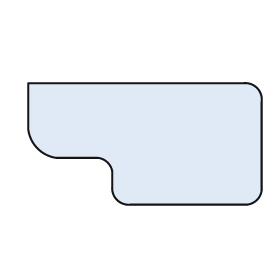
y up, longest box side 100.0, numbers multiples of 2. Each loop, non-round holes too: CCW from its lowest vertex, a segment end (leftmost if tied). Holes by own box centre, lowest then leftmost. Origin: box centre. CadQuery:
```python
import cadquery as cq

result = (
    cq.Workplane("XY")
    .moveTo(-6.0, -26.0)
    .lineTo(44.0, -26.0)
    .threePointArc((48.0, -24.0), (50.0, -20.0))
    .lineTo(50.0, 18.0)
    .threePointArc((48.0, 24.0), (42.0, 26.0))
    .lineTo(-50.0, 26.0)
    .lineTo(-50.0, 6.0)
    .threePointArc((-46.0, -2.0), (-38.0, -6.0))
    .lineTo(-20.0, -6.0)
    .threePointArc((-16.0, -8.0), (-14.0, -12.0))
    .lineTo(-14.0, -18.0)
    .threePointArc((-12.0, -24.0), (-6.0, -26.0))
    .close()
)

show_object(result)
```